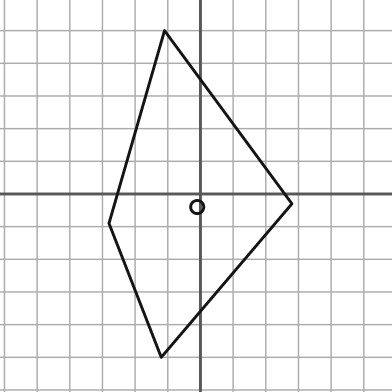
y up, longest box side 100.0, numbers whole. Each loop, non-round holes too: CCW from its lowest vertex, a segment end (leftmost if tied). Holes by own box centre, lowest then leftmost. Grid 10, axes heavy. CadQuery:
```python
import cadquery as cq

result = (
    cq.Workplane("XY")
    .moveTo(-12.0, -50.0)
    .lineTo(28.0, -3.0)
    .lineTo(-11.0, 50.0)
    .lineTo(-28.0, -9.0)
    .close()
    .moveTo(-1.0, -4.0)
    .circle(2.0)
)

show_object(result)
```